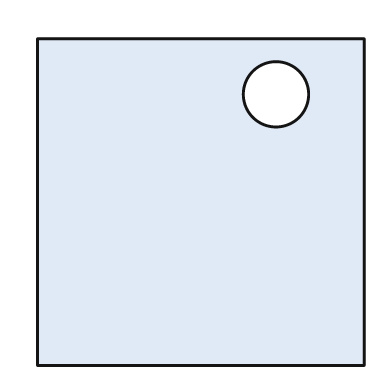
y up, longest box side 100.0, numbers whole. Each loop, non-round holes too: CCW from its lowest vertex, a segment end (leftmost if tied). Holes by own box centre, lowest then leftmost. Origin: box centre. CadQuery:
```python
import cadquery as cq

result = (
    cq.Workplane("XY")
    .moveTo(-50.0, -50.0)
    .lineTo(50.0, -50.0)
    .lineTo(50.0, 50.0)
    .lineTo(-50.0, 50.0)
    .close()
    .moveTo(23.0, 33.0)
    .circle(10.0)
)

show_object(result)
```